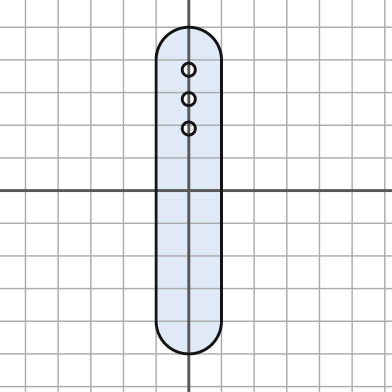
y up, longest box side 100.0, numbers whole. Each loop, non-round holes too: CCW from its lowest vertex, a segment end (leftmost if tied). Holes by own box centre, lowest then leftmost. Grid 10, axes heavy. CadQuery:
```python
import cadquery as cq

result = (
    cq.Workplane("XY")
    .moveTo(-10.0, -40.0)
    .threePointArc((0.0, -50.0), (10.0, -40.0))
    .lineTo(10.0, 40.0)
    .threePointArc((0.0, 50.0), (-10.0, 40.0))
    .close()
    .moveTo(0.0, 19.0)
    .circle(2.0)
    .moveTo(0.0, 28.0)
    .circle(2.0)
    .moveTo(0.0, 37.0)
    .circle(2.0)
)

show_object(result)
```